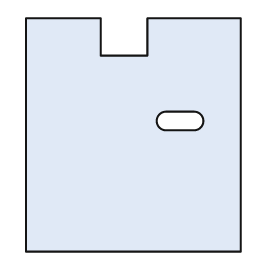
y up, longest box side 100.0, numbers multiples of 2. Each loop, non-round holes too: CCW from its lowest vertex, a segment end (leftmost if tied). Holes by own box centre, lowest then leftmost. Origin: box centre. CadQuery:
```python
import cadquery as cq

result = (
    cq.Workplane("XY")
    .moveTo(-46.0, -50.0)
    .lineTo(46.0, -50.0)
    .lineTo(46.0, 50.0)
    .lineTo(6.0, 50.0)
    .lineTo(6.0, 34.0)
    .lineTo(-14.0, 34.0)
    .lineTo(-14.0, 50.0)
    .lineTo(-46.0, 50.0)
    .close()
    .moveTo(14.0, 2.0)
    .lineTo(26.0, 2.0)
    .threePointArc((30.0, 6.0), (26.0, 10.0))
    .lineTo(14.0, 10.0)
    .threePointArc((10.0, 6.0), (14.0, 2.0))
    .close()
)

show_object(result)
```